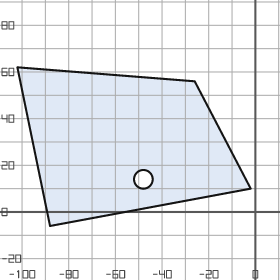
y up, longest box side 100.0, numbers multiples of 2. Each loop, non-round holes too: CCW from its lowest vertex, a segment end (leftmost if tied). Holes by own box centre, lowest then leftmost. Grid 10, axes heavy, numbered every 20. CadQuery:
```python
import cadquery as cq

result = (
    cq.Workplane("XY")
    .moveTo(-88.0, -6.0)
    .lineTo(-2.0, 10.0)
    .lineTo(-26.0, 56.0)
    .lineTo(-102.0, 62.0)
    .close()
    .moveTo(-48.0, 14.0)
    .circle(4.0)
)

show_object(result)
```